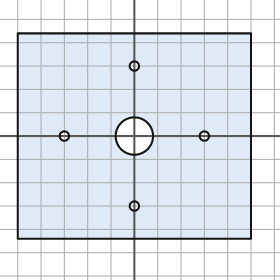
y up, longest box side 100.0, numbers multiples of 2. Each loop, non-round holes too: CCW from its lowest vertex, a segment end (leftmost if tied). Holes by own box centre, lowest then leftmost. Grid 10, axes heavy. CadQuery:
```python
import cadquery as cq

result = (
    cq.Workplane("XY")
    .moveTo(-50.0, -44.0)
    .lineTo(50.0, -44.0)
    .lineTo(50.0, 44.0)
    .lineTo(-50.0, 44.0)
    .close()
    .moveTo(0.0, -30.0)
    .circle(2.0)
    .moveTo(-30.0, 0.0)
    .circle(2.0)
    .moveTo(0.0, 0.0)
    .circle(8.0)
    .moveTo(30.0, 0.0)
    .circle(2.0)
    .moveTo(0.0, 30.0)
    .circle(2.0)
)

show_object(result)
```